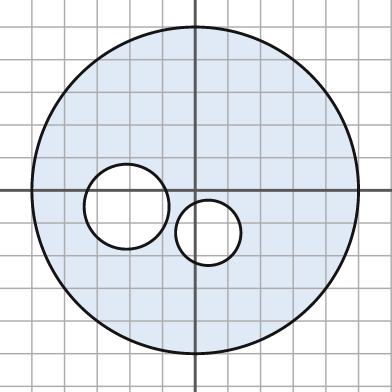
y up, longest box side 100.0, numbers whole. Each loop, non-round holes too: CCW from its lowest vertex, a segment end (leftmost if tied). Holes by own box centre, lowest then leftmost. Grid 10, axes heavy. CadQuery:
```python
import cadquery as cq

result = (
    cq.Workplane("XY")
    .moveTo(0.0, 0.0)
    .circle(50.0)
    .moveTo(4.0, -13.0)
    .circle(10.0)
    .moveTo(-21.0, -5.0)
    .circle(13.0)
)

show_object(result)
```